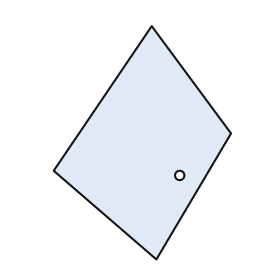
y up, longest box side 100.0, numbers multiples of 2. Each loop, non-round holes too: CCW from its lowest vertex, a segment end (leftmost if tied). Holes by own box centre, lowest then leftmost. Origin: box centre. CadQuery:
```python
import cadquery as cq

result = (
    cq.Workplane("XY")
    .moveTo(6.0, -50.0)
    .lineTo(38.0, 4.0)
    .lineTo(4.0, 50.0)
    .lineTo(-38.0, -12.0)
    .close()
    .moveTo(16.0, -14.0)
    .circle(2.0)
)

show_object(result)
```